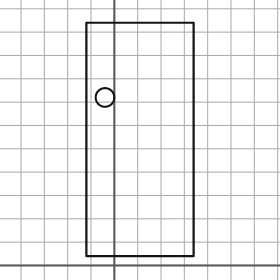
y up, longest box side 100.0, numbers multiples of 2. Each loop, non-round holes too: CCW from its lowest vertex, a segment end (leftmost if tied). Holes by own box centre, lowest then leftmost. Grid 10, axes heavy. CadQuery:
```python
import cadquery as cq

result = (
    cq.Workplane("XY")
    .moveTo(-12.0, 4.0)
    .lineTo(34.0, 4.0)
    .lineTo(34.0, 104.0)
    .lineTo(-12.0, 104.0)
    .close()
    .moveTo(-4.0, 72.0)
    .circle(4.0)
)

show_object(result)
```